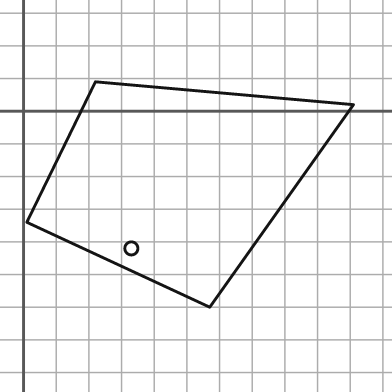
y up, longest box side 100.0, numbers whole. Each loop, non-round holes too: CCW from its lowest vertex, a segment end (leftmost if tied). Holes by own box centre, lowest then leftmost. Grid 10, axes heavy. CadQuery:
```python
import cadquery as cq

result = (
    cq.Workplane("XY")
    .moveTo(57.0, -60.0)
    .lineTo(101.0, 2.0)
    .lineTo(22.0, 9.0)
    .lineTo(1.0, -34.0)
    .close()
    .moveTo(33.0, -42.0)
    .circle(2.0)
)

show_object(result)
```